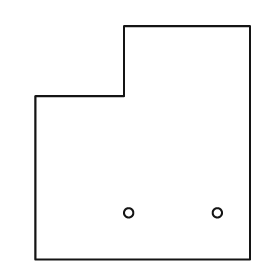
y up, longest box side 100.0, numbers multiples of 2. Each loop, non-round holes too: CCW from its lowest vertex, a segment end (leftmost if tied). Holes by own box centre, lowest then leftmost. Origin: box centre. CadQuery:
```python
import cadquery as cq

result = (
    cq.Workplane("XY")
    .moveTo(-46.0, -50.0)
    .lineTo(46.0, -50.0)
    .lineTo(46.0, 50.0)
    .lineTo(-8.0, 50.0)
    .lineTo(-8.0, 20.0)
    .lineTo(-46.0, 20.0)
    .close()
    .moveTo(-6.0, -30.0)
    .circle(2.0)
    .moveTo(32.0, -30.0)
    .circle(2.0)
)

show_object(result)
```